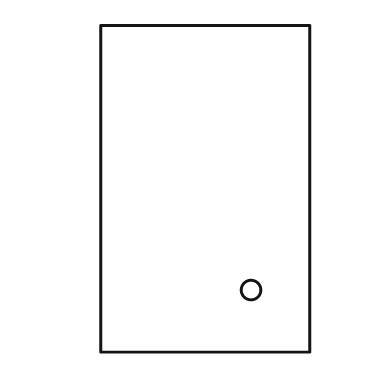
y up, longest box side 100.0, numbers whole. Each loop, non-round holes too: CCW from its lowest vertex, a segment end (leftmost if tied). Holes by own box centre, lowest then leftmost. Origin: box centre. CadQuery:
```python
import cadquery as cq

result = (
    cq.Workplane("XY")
    .moveTo(-32.0, -50.0)
    .lineTo(32.0, -50.0)
    .lineTo(32.0, 50.0)
    .lineTo(-32.0, 50.0)
    .close()
    .moveTo(14.0, -31.0)
    .circle(3.0)
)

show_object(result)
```